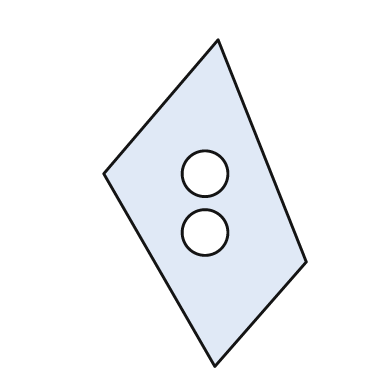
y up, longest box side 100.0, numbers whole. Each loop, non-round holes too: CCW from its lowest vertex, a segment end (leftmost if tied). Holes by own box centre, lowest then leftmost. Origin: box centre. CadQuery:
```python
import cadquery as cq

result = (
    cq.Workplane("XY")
    .moveTo(3.0, -50.0)
    .lineTo(31.0, -18.0)
    .lineTo(4.0, 50.0)
    .lineTo(-31.0, 9.0)
    .close()
    .moveTo(0.0, -9.0)
    .circle(7.0)
    .moveTo(0.0, 9.0)
    .circle(7.0)
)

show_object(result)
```